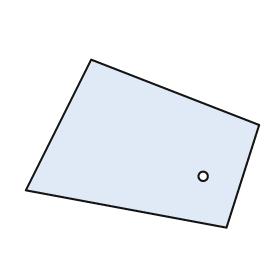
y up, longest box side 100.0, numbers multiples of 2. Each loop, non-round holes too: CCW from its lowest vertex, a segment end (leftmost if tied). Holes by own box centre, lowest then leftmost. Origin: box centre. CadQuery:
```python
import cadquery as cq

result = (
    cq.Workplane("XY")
    .moveTo(36.0, -36.0)
    .lineTo(50.0, 8.0)
    .lineTo(-22.0, 36.0)
    .lineTo(-50.0, -20.0)
    .close()
    .moveTo(26.0, -14.0)
    .circle(2.0)
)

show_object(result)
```